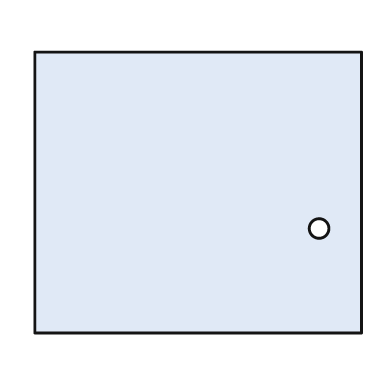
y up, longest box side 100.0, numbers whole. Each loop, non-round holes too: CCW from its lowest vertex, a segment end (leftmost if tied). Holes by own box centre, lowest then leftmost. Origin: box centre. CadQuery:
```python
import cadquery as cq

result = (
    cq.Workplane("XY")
    .moveTo(-50.0, -43.0)
    .lineTo(50.0, -43.0)
    .lineTo(50.0, 43.0)
    .lineTo(-50.0, 43.0)
    .close()
    .moveTo(37.0, -11.0)
    .circle(3.0)
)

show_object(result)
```